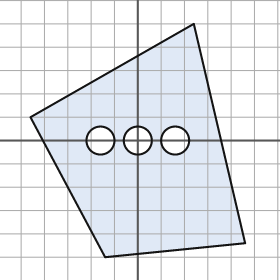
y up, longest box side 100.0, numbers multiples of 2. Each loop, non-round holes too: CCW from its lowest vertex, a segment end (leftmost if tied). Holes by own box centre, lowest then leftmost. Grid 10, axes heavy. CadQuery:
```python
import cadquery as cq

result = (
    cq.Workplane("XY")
    .moveTo(-14.0, -50.0)
    .lineTo(46.0, -44.0)
    .lineTo(24.0, 50.0)
    .lineTo(-46.0, 10.0)
    .close()
    .moveTo(-16.0, 0.0)
    .circle(6.0)
    .moveTo(0.0, 0.0)
    .circle(6.0)
    .moveTo(16.0, 0.0)
    .circle(6.0)
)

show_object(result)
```